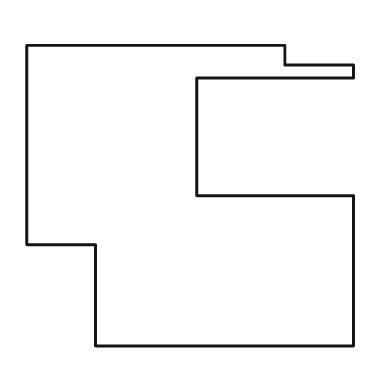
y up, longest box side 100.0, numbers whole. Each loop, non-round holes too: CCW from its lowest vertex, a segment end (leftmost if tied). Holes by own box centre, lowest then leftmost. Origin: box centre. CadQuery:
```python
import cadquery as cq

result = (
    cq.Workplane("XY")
    .moveTo(-29.0, -46.0)
    .lineTo(50.0, -46.0)
    .lineTo(50.0, 0.0)
    .lineTo(2.0, 0.0)
    .lineTo(2.0, 36.0)
    .lineTo(50.0, 36.0)
    .lineTo(50.0, 40.0)
    .lineTo(29.0, 40.0)
    .lineTo(29.0, 46.0)
    .lineTo(-50.0, 46.0)
    .lineTo(-50.0, -15.0)
    .lineTo(-29.0, -15.0)
    .close()
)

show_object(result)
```